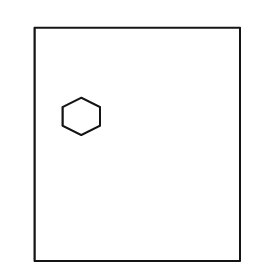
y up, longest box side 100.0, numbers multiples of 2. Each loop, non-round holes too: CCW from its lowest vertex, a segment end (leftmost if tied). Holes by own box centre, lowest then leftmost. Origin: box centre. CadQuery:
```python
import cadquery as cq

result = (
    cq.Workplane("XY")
    .moveTo(-44.0, -50.0)
    .lineTo(44.0, -50.0)
    .lineTo(44.0, 50.0)
    .lineTo(-44.0, 50.0)
    .close()
    .moveTo(-24.0, 4.0)
    .lineTo(-16.0, 8.0)
    .lineTo(-16.0, 16.0)
    .lineTo(-24.0, 20.0)
    .lineTo(-32.0, 16.0)
    .lineTo(-32.0, 8.0)
    .close()
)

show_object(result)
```